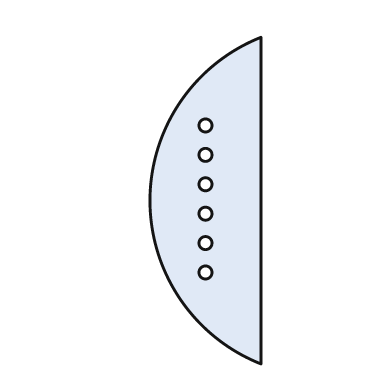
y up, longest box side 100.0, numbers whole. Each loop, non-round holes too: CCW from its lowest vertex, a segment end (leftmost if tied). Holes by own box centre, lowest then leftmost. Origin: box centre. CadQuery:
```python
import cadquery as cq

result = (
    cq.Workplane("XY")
    .moveTo(17.0, -50.0)
    .lineTo(17.0, 50.0)
    .threePointArc((-17.0, 0.0), (17.0, -50.0))
    .close()
    .moveTo(0.0, -22.0)
    .circle(2.0)
    .moveTo(0.0, -13.0)
    .circle(2.0)
    .moveTo(0.0, -4.0)
    .circle(2.0)
    .moveTo(0.0, 5.0)
    .circle(2.0)
    .moveTo(0.0, 14.0)
    .circle(2.0)
    .moveTo(0.0, 23.0)
    .circle(2.0)
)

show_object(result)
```